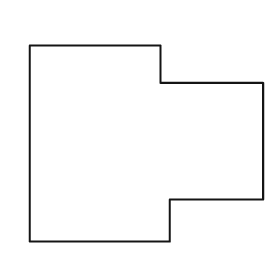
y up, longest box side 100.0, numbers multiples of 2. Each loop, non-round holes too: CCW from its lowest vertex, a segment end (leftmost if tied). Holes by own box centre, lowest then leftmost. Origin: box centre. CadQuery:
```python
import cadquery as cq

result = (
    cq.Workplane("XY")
    .moveTo(-50.0, -42.0)
    .lineTo(10.0, -42.0)
    .lineTo(10.0, -24.0)
    .lineTo(50.0, -24.0)
    .lineTo(50.0, 26.0)
    .lineTo(6.0, 26.0)
    .lineTo(6.0, 42.0)
    .lineTo(-50.0, 42.0)
    .close()
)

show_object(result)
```